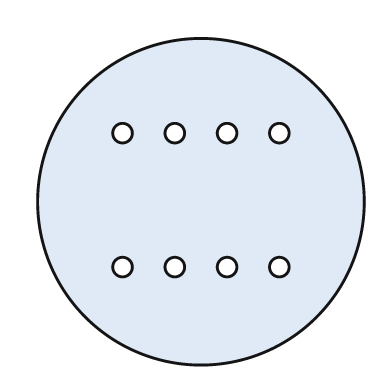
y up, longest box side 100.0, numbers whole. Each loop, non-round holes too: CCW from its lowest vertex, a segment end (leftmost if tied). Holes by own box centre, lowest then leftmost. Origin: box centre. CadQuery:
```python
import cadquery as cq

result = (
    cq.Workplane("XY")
    .moveTo(0.0, 0.0)
    .circle(50.0)
    .moveTo(-24.0, -20.0)
    .circle(3.0)
    .moveTo(-8.0, -20.0)
    .circle(3.0)
    .moveTo(8.0, -20.0)
    .circle(3.0)
    .moveTo(24.0, -20.0)
    .circle(3.0)
    .moveTo(-24.0, 21.0)
    .circle(3.0)
    .moveTo(-8.0, 21.0)
    .circle(3.0)
    .moveTo(8.0, 21.0)
    .circle(3.0)
    .moveTo(24.0, 21.0)
    .circle(3.0)
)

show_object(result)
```